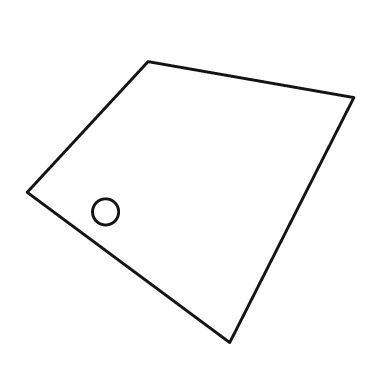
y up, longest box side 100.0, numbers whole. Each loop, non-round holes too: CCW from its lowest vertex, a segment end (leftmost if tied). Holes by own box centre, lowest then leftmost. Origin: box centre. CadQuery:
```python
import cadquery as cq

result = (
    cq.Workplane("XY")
    .moveTo(12.0, -43.0)
    .lineTo(50.0, 32.0)
    .lineTo(-13.0, 43.0)
    .lineTo(-50.0, 3.0)
    .close()
    .moveTo(-26.0, -3.0)
    .circle(4.0)
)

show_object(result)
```